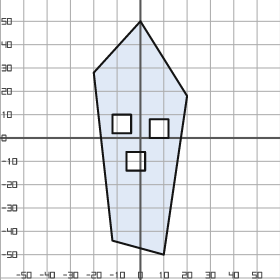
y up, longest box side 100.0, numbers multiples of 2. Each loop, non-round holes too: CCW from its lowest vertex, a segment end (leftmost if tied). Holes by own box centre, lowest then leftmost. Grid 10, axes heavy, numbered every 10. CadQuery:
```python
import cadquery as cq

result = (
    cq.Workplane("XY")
    .moveTo(10.0, -50.0)
    .lineTo(20.0, 18.0)
    .lineTo(0.0, 50.0)
    .lineTo(-20.0, 28.0)
    .lineTo(-12.0, -44.0)
    .close()
    .moveTo(-6.0, -14.0)
    .lineTo(2.0, -14.0)
    .lineTo(2.0, -6.0)
    .lineTo(-6.0, -6.0)
    .close()
    .moveTo(4.0, 0.0)
    .lineTo(12.0, 0.0)
    .lineTo(12.0, 8.0)
    .lineTo(4.0, 8.0)
    .close()
    .moveTo(-12.0, 2.0)
    .lineTo(-4.0, 2.0)
    .lineTo(-4.0, 10.0)
    .lineTo(-12.0, 10.0)
    .close()
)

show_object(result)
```